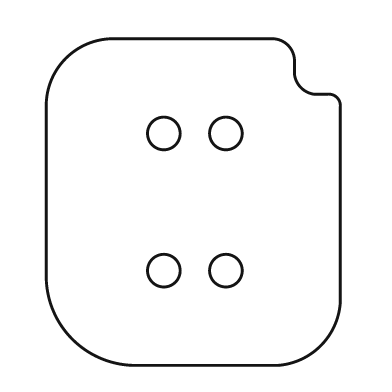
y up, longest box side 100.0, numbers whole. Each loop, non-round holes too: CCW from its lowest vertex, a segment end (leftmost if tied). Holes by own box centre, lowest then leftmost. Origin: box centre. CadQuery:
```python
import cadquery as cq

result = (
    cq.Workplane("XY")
    .moveTo(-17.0, -50.0)
    .lineTo(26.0, -50.0)
    .threePointArc((39.0, -44.0), (45.0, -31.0))
    .lineTo(45.0, 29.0)
    .threePointArc((44.0, 32.0), (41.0, 33.0))
    .lineTo(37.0, 33.0)
    .threePointArc((33.0, 35.0), (31.0, 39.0))
    .lineTo(31.0, 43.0)
    .threePointArc((29.0, 48.0), (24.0, 50.0))
    .lineTo(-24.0, 50.0)
    .threePointArc((-39.0, 44.0), (-45.0, 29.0))
    .lineTo(-45.0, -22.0)
    .threePointArc((-37.0, -42.0), (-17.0, -50.0))
    .close()
    .moveTo(-9.0, -21.0)
    .circle(5.0)
    .moveTo(10.0, -21.0)
    .circle(5.0)
    .moveTo(-9.0, 21.0)
    .circle(5.0)
    .moveTo(10.0, 21.0)
    .circle(5.0)
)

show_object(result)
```